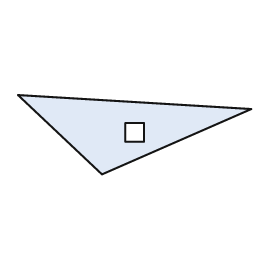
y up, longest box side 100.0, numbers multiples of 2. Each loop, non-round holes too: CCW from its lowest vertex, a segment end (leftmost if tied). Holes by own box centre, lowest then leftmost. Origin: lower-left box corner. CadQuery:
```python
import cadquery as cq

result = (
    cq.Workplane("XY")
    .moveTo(36.0, 0.0)
    .lineTo(100.0, 28.0)
    .lineTo(0.0, 34.0)
    .close()
    .moveTo(46.0, 14.0)
    .lineTo(54.0, 14.0)
    .lineTo(54.0, 22.0)
    .lineTo(46.0, 22.0)
    .close()
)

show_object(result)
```